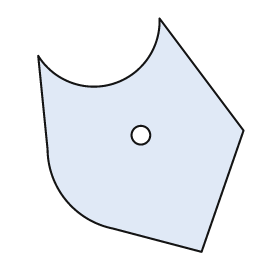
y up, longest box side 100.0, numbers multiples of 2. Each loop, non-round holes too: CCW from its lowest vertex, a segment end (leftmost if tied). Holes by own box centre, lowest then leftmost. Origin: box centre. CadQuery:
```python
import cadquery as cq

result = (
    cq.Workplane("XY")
    .moveTo(26.0, -50.0)
    .lineTo(44.0, 2.0)
    .lineTo(8.0, 50.0)
    .threePointArc((-12.0, 22.0), (-44.0, 34.0))
    .lineTo(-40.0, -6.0)
    .threePointArc((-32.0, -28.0), (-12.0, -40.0))
    .close()
    .moveTo(0.0, 0.0)
    .circle(4.0)
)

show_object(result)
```